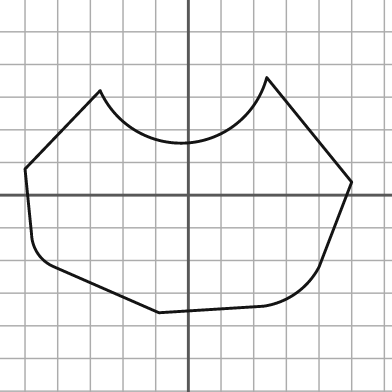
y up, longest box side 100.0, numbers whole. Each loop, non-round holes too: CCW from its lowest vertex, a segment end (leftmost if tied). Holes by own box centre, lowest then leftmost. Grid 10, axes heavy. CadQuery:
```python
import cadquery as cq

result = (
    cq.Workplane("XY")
    .moveTo(-9.0, -36.0)
    .lineTo(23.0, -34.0)
    .threePointArc((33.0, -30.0), (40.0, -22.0))
    .lineTo(50.0, 4.0)
    .lineTo(24.0, 36.0)
    .threePointArc((0.0, 16.0), (-27.0, 32.0))
    .lineTo(-50.0, 8.0)
    .lineTo(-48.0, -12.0)
    .threePointArc((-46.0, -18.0), (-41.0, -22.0))
    .close()
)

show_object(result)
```